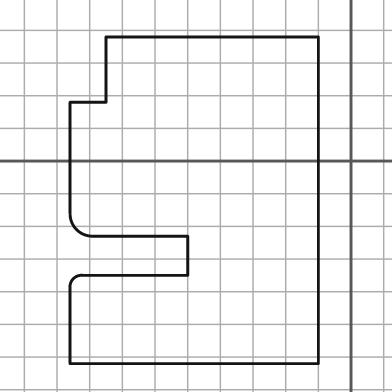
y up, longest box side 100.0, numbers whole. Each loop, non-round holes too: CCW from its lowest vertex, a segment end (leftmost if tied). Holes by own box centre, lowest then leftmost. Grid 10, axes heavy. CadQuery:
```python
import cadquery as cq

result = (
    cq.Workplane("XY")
    .moveTo(-86.0, -62.0)
    .lineTo(-10.0, -62.0)
    .lineTo(-10.0, 38.0)
    .lineTo(-75.0, 38.0)
    .lineTo(-75.0, 18.0)
    .lineTo(-86.0, 18.0)
    .lineTo(-86.0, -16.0)
    .threePointArc((-84.0, -21.0), (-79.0, -23.0))
    .lineTo(-50.0, -23.0)
    .lineTo(-50.0, -35.0)
    .lineTo(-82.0, -35.0)
    .threePointArc((-85.0, -36.0), (-86.0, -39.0))
    .close()
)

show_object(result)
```